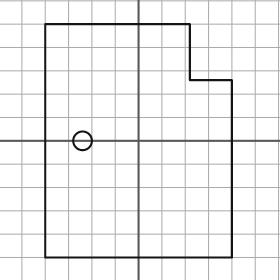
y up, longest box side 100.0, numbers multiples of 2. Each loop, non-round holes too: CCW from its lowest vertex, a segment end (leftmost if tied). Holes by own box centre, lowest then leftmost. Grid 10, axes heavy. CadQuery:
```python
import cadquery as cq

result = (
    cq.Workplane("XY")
    .moveTo(-40.0, -50.0)
    .lineTo(40.0, -50.0)
    .lineTo(40.0, 26.0)
    .lineTo(22.0, 26.0)
    .lineTo(22.0, 50.0)
    .lineTo(-40.0, 50.0)
    .close()
    .moveTo(-24.0, 0.0)
    .circle(4.0)
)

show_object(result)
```